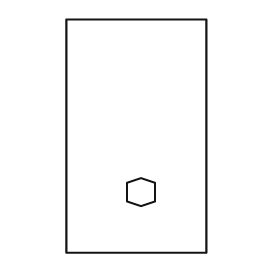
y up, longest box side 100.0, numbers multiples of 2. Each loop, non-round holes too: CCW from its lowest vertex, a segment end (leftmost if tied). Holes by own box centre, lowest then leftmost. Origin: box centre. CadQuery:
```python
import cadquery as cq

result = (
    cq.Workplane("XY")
    .moveTo(-30.0, -50.0)
    .lineTo(30.0, -50.0)
    .lineTo(30.0, 50.0)
    .lineTo(-30.0, 50.0)
    .close()
    .moveTo(2.0, -30.0)
    .lineTo(8.0, -28.0)
    .lineTo(8.0, -20.0)
    .lineTo(2.0, -18.0)
    .lineTo(-4.0, -20.0)
    .lineTo(-4.0, -28.0)
    .close()
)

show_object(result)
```